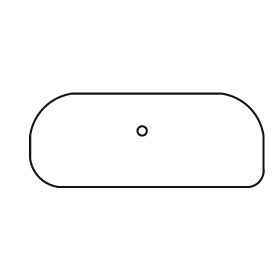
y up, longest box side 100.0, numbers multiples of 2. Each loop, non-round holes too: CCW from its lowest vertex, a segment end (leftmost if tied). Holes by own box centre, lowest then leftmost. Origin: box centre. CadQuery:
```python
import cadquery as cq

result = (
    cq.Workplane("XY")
    .moveTo(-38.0, -20.0)
    .lineTo(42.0, -20.0)
    .threePointArc((48.0, -18.0), (50.0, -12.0))
    .lineTo(50.0, 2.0)
    .threePointArc((44.0, 14.0), (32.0, 20.0))
    .lineTo(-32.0, 20.0)
    .threePointArc((-44.0, 14.0), (-50.0, 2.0))
    .lineTo(-50.0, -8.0)
    .threePointArc((-46.0, -16.0), (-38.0, -20.0))
    .close()
    .moveTo(-2.0, 4.0)
    .circle(2.0)
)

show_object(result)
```